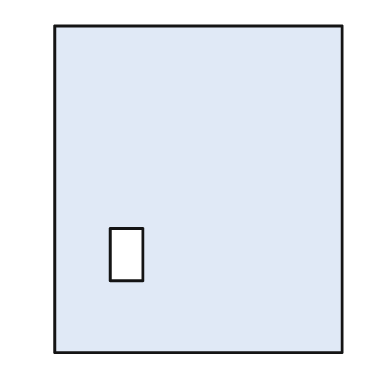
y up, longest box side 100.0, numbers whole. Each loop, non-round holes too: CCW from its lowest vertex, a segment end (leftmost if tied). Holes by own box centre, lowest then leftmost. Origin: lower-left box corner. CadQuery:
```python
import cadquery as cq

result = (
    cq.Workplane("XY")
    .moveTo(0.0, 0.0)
    .lineTo(88.0, 0.0)
    .lineTo(88.0, 100.0)
    .lineTo(0.0, 100.0)
    .close()
    .moveTo(17.0, 22.0)
    .lineTo(27.0, 22.0)
    .lineTo(27.0, 38.0)
    .lineTo(17.0, 38.0)
    .close()
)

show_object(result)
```